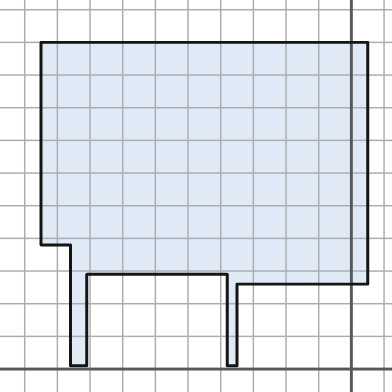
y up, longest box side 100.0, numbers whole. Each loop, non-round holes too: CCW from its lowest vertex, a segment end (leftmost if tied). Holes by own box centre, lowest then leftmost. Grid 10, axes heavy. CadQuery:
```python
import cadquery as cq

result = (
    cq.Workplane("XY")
    .moveTo(-86.0, 1.0)
    .lineTo(-81.0, 1.0)
    .lineTo(-81.0, 29.0)
    .lineTo(-38.0, 29.0)
    .lineTo(-38.0, 1.0)
    .lineTo(-35.0, 1.0)
    .lineTo(-35.0, 26.0)
    .lineTo(5.0, 26.0)
    .lineTo(5.0, 100.0)
    .lineTo(-95.0, 100.0)
    .lineTo(-95.0, 38.0)
    .lineTo(-86.0, 38.0)
    .close()
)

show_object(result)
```